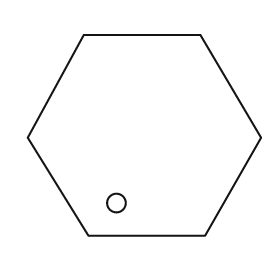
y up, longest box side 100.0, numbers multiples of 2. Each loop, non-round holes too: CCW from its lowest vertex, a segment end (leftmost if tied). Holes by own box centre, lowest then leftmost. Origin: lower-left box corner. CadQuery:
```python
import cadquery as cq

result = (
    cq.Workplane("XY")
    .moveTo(26.0, 0.0)
    .lineTo(76.0, 0.0)
    .lineTo(100.0, 42.0)
    .lineTo(74.0, 86.0)
    .lineTo(24.0, 86.0)
    .lineTo(0.0, 42.0)
    .close()
    .moveTo(38.0, 14.0)
    .circle(4.0)
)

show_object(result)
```